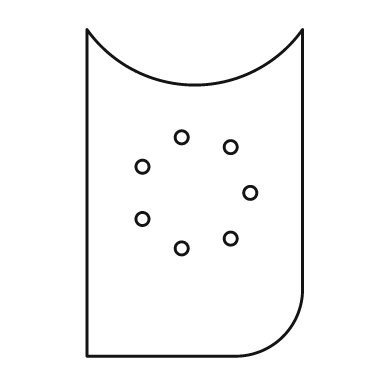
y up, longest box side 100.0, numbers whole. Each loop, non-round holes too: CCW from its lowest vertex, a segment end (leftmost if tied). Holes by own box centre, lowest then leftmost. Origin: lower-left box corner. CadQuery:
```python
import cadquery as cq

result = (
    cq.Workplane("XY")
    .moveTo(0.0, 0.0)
    .lineTo(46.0, 0.0)
    .threePointArc((60.0, 6.0), (66.0, 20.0))
    .lineTo(66.0, 100.0)
    .threePointArc((33.0, 83.0), (0.0, 100.0))
    .close()
    .moveTo(29.0, 33.0)
    .circle(2.0)
    .moveTo(44.0, 36.0)
    .circle(2.0)
    .moveTo(17.0, 42.0)
    .circle(2.0)
    .moveTo(50.0, 50.0)
    .circle(2.0)
    .moveTo(17.0, 58.0)
    .circle(2.0)
    .moveTo(44.0, 64.0)
    .circle(2.0)
    .moveTo(29.0, 67.0)
    .circle(2.0)
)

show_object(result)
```